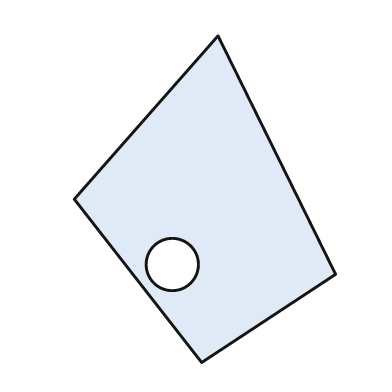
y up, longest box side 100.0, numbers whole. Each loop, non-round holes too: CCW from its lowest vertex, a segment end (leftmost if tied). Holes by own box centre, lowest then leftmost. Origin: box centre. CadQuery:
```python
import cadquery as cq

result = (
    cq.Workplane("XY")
    .moveTo(-1.0, -50.0)
    .lineTo(40.0, -23.0)
    .lineTo(4.0, 50.0)
    .lineTo(-40.0, 0.0)
    .close()
    .moveTo(-10.0, -20.0)
    .circle(8.0)
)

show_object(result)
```